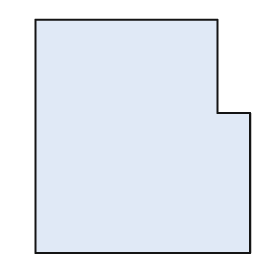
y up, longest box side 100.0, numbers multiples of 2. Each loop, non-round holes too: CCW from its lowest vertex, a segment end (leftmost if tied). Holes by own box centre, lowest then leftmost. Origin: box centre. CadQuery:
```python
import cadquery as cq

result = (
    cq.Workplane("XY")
    .moveTo(-46.0, -50.0)
    .lineTo(46.0, -50.0)
    .lineTo(46.0, 10.0)
    .lineTo(32.0, 10.0)
    .lineTo(32.0, 50.0)
    .lineTo(-46.0, 50.0)
    .close()
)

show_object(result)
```